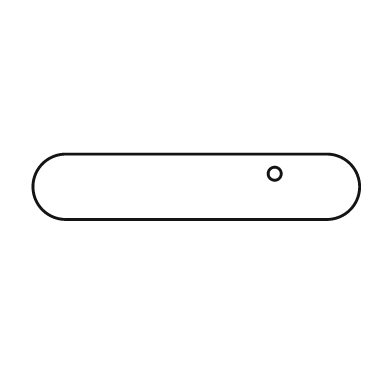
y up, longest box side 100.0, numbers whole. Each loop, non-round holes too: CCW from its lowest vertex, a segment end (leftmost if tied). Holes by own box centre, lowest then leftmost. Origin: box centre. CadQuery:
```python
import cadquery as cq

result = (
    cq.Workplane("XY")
    .moveTo(-40.0, -10.0)
    .lineTo(40.0, -10.0)
    .threePointArc((50.0, 0.0), (40.0, 10.0))
    .lineTo(-40.0, 10.0)
    .threePointArc((-50.0, 0.0), (-40.0, -10.0))
    .close()
    .moveTo(24.0, 4.0)
    .circle(2.0)
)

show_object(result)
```